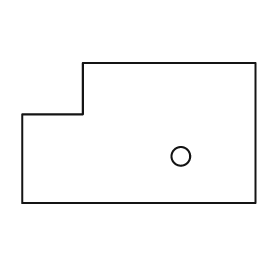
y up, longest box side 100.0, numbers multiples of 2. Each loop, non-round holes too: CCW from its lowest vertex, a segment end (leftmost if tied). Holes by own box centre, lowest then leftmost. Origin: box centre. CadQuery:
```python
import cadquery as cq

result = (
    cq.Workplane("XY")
    .moveTo(-50.0, -30.0)
    .lineTo(50.0, -30.0)
    .lineTo(50.0, 30.0)
    .lineTo(-24.0, 30.0)
    .lineTo(-24.0, 8.0)
    .lineTo(-50.0, 8.0)
    .close()
    .moveTo(18.0, -10.0)
    .circle(4.0)
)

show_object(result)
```